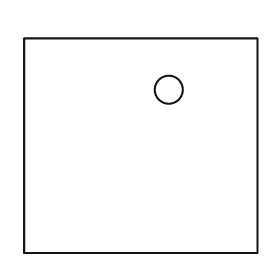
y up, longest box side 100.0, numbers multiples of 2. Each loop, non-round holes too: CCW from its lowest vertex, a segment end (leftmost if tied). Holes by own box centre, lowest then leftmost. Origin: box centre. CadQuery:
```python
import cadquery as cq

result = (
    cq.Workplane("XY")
    .moveTo(-50.0, -46.0)
    .lineTo(50.0, -46.0)
    .lineTo(50.0, 46.0)
    .lineTo(-50.0, 46.0)
    .close()
    .moveTo(12.0, 24.0)
    .circle(6.0)
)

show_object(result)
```